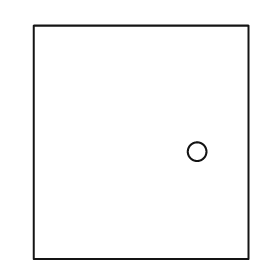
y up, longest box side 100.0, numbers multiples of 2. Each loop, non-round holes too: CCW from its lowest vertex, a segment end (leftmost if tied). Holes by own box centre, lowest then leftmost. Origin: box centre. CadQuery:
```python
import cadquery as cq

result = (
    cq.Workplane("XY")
    .moveTo(-46.0, -50.0)
    .lineTo(46.0, -50.0)
    .lineTo(46.0, 50.0)
    .lineTo(-46.0, 50.0)
    .close()
    .moveTo(24.0, -4.0)
    .circle(4.0)
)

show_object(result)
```